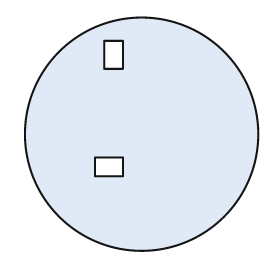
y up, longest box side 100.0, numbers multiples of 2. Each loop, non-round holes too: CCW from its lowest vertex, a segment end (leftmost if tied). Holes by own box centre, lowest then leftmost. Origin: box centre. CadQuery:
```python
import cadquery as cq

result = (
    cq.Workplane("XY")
    .moveTo(0.0, 0.0)
    .circle(50.0)
    .moveTo(-20.0, -18.0)
    .lineTo(-8.0, -18.0)
    .lineTo(-8.0, -10.0)
    .lineTo(-20.0, -10.0)
    .close()
    .moveTo(-16.0, 28.0)
    .lineTo(-8.0, 28.0)
    .lineTo(-8.0, 40.0)
    .lineTo(-16.0, 40.0)
    .close()
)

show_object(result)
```